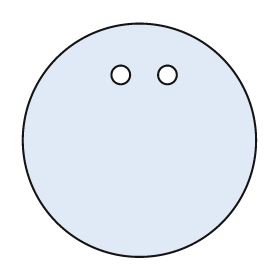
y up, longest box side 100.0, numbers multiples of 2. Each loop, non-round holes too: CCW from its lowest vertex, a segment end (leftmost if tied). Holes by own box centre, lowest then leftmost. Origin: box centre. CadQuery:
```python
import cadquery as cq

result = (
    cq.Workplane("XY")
    .moveTo(0.0, 0.0)
    .circle(50.0)
    .moveTo(-8.0, 28.0)
    .circle(4.0)
    .moveTo(12.0, 28.0)
    .circle(4.0)
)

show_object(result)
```